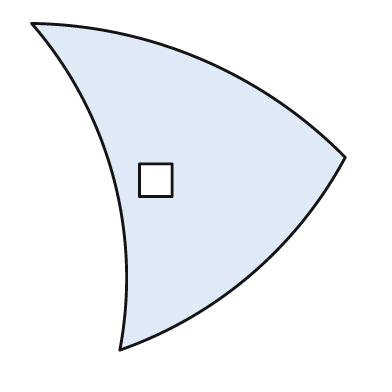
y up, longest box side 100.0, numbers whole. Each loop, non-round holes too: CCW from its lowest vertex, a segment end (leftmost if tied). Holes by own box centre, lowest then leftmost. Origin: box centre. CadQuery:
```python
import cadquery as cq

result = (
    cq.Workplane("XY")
    .moveTo(-21.0, -50.0)
    .threePointArc((19.0, -27.0), (48.0, 9.0))
    .threePointArc((4.0, 39.0), (-48.0, 50.0))
    .threePointArc((-23.0, 3.0), (-21.0, -50.0))
    .close()
    .moveTo(-15.0, -3.0)
    .lineTo(-5.0, -3.0)
    .lineTo(-5.0, 7.0)
    .lineTo(-15.0, 7.0)
    .close()
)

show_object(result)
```